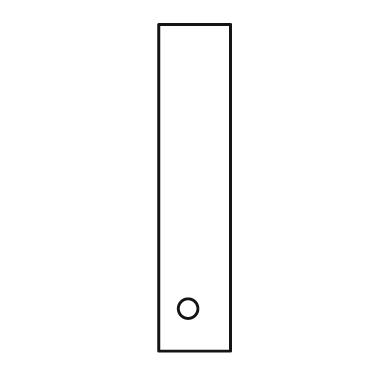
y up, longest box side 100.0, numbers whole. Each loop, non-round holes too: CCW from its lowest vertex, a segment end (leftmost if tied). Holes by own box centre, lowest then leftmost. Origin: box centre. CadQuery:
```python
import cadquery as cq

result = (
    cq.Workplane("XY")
    .moveTo(-11.0, -50.0)
    .lineTo(11.0, -50.0)
    .lineTo(11.0, 50.0)
    .lineTo(-11.0, 50.0)
    .close()
    .moveTo(-2.0, -37.0)
    .circle(3.0)
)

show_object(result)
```